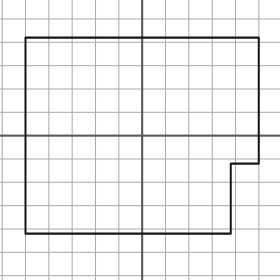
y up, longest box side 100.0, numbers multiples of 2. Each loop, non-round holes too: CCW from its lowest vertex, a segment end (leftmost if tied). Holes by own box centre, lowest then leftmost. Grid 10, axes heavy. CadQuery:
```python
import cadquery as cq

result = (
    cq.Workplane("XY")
    .moveTo(-50.0, -42.0)
    .lineTo(38.0, -42.0)
    .lineTo(38.0, -12.0)
    .lineTo(50.0, -12.0)
    .lineTo(50.0, 42.0)
    .lineTo(-50.0, 42.0)
    .close()
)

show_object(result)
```